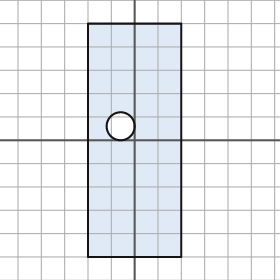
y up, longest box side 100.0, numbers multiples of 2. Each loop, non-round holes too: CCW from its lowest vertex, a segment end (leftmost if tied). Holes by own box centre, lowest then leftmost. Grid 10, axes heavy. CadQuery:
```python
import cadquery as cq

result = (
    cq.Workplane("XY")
    .moveTo(-20.0, -50.0)
    .lineTo(20.0, -50.0)
    .lineTo(20.0, 50.0)
    .lineTo(-20.0, 50.0)
    .close()
    .moveTo(-6.0, 6.0)
    .circle(6.0)
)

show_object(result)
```